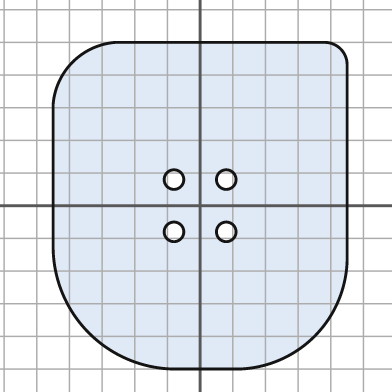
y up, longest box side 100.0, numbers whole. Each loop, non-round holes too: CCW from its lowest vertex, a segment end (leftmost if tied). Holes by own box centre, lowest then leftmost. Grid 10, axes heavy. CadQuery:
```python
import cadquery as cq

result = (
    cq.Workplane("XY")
    .moveTo(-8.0, -50.0)
    .lineTo(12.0, -50.0)
    .threePointArc((35.0, -40.0), (45.0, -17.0))
    .lineTo(45.0, 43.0)
    .threePointArc((43.0, 48.0), (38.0, 50.0))
    .lineTo(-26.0, 50.0)
    .threePointArc((-39.0, 44.0), (-45.0, 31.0))
    .lineTo(-45.0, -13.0)
    .threePointArc((-34.0, -39.0), (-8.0, -50.0))
    .close()
    .moveTo(-8.0, -8.0)
    .circle(3.0)
    .moveTo(8.0, -8.0)
    .circle(3.0)
    .moveTo(-8.0, 8.0)
    .circle(3.0)
    .moveTo(8.0, 8.0)
    .circle(3.0)
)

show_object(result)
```